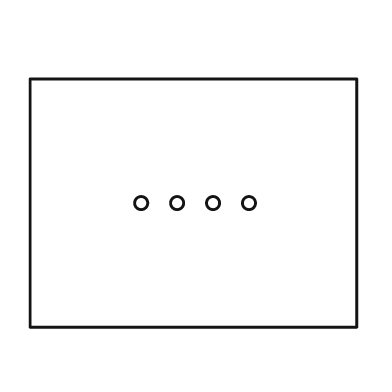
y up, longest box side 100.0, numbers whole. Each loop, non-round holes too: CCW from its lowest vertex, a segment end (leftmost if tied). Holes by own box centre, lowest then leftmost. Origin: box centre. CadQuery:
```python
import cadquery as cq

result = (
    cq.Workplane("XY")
    .moveTo(-50.0, -38.0)
    .lineTo(50.0, -38.0)
    .lineTo(50.0, 38.0)
    .lineTo(-50.0, 38.0)
    .close()
    .moveTo(-16.0, 0.0)
    .circle(2.0)
    .moveTo(-5.0, 0.0)
    .circle(2.0)
    .moveTo(6.0, 0.0)
    .circle(2.0)
    .moveTo(17.0, 0.0)
    .circle(2.0)
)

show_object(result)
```